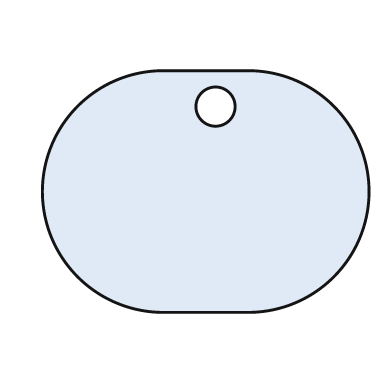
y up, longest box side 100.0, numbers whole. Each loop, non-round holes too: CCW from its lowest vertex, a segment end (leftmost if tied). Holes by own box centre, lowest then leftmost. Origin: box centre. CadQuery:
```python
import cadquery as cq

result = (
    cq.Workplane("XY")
    .moveTo(-13.0, -37.0)
    .lineTo(13.0, -37.0)
    .threePointArc((50.0, 0.0), (13.0, 37.0))
    .lineTo(-13.0, 37.0)
    .threePointArc((-50.0, 0.0), (-13.0, -37.0))
    .close()
    .moveTo(3.0, 26.0)
    .circle(6.0)
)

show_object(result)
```